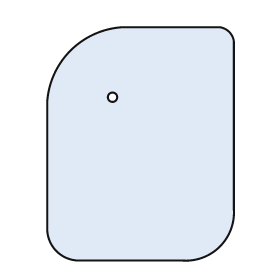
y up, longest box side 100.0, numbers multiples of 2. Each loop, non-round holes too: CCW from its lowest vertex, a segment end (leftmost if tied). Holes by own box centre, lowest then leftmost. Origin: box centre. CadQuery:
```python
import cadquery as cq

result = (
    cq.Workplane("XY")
    .moveTo(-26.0, -50.0)
    .lineTo(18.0, -50.0)
    .threePointArc((34.0, -44.0), (40.0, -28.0))
    .lineTo(40.0, 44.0)
    .threePointArc((38.0, 48.0), (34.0, 50.0))
    .lineTo(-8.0, 50.0)
    .threePointArc((-30.0, 40.0), (-40.0, 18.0))
    .lineTo(-40.0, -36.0)
    .threePointArc((-36.0, -46.0), (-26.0, -50.0))
    .close()
    .moveTo(-12.0, 20.0)
    .circle(2.0)
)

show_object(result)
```